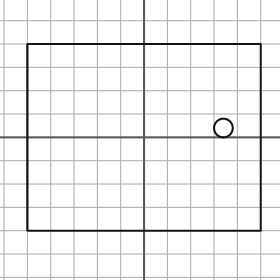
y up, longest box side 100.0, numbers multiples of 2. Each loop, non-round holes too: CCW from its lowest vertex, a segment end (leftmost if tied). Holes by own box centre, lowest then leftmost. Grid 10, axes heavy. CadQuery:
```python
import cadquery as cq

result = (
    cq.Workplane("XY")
    .moveTo(-50.0, -40.0)
    .lineTo(50.0, -40.0)
    .lineTo(50.0, 40.0)
    .lineTo(-50.0, 40.0)
    .close()
    .moveTo(34.0, 4.0)
    .circle(4.0)
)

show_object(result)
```